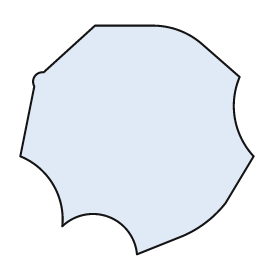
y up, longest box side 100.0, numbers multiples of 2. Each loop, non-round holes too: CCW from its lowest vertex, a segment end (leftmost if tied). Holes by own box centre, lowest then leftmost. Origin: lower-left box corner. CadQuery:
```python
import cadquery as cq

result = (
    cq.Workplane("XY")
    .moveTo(50.0, 0.0)
    .lineTo(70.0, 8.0)
    .threePointArc((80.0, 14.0), (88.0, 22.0))
    .lineTo(100.0, 42.0)
    .threePointArc((92.0, 58.0), (94.0, 76.0))
    .lineTo(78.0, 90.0)
    .threePointArc((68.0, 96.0), (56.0, 98.0))
    .lineTo(32.0, 98.0)
    .lineTo(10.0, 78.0)
    .threePointArc((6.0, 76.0), (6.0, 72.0))
    .lineTo(0.0, 42.0)
    .threePointArc((14.0, 30.0), (18.0, 12.0))
    .threePointArc((38.0, 16.0), (50.0, 0.0))
    .close()
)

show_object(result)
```